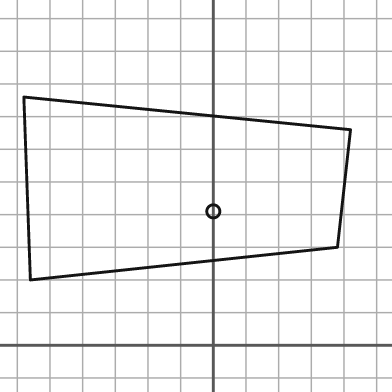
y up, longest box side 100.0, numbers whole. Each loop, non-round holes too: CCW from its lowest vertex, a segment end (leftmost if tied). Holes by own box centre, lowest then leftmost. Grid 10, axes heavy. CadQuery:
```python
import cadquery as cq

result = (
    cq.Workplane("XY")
    .moveTo(-56.0, 20.0)
    .lineTo(38.0, 30.0)
    .lineTo(42.0, 66.0)
    .lineTo(-58.0, 76.0)
    .close()
    .moveTo(0.0, 41.0)
    .circle(2.0)
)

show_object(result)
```